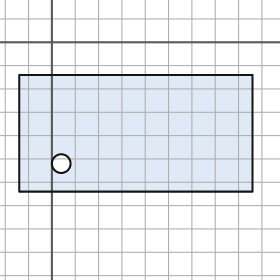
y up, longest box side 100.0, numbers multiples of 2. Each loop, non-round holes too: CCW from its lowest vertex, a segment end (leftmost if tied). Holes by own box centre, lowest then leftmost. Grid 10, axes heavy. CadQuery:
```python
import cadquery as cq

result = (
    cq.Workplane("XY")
    .moveTo(-14.0, -64.0)
    .lineTo(86.0, -64.0)
    .lineTo(86.0, -14.0)
    .lineTo(-14.0, -14.0)
    .close()
    .moveTo(4.0, -52.0)
    .circle(4.0)
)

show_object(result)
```